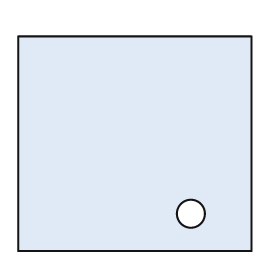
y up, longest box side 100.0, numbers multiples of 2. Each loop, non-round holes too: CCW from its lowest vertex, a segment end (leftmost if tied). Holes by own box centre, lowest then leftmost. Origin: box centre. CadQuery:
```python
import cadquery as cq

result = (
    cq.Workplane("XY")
    .moveTo(-50.0, -46.0)
    .lineTo(50.0, -46.0)
    .lineTo(50.0, 46.0)
    .lineTo(-50.0, 46.0)
    .close()
    .moveTo(24.0, -30.0)
    .circle(6.0)
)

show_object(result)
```